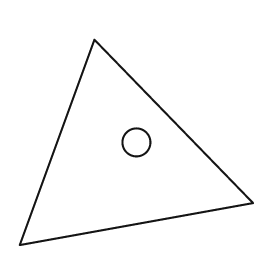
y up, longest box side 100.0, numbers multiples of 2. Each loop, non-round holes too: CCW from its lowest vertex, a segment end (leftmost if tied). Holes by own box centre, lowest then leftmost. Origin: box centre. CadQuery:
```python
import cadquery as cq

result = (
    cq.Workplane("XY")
    .moveTo(-50.0, -44.0)
    .lineTo(50.0, -26.0)
    .lineTo(-18.0, 44.0)
    .close()
    .moveTo(0.0, 0.0)
    .circle(6.0)
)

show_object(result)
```